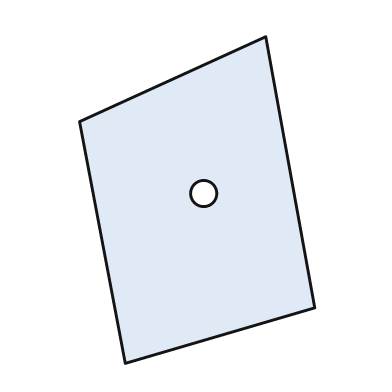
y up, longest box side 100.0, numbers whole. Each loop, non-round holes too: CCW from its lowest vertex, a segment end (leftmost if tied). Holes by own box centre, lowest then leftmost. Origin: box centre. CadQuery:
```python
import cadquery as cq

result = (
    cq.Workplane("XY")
    .moveTo(-22.0, -50.0)
    .lineTo(36.0, -33.0)
    .lineTo(21.0, 50.0)
    .lineTo(-36.0, 24.0)
    .close()
    .moveTo(2.0, 2.0)
    .circle(4.0)
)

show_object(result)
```